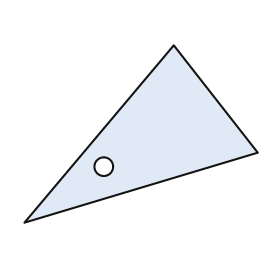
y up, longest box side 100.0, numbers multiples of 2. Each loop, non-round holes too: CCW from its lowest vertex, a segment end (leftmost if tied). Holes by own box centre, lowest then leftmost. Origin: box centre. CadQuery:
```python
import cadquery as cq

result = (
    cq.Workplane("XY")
    .moveTo(-50.0, -38.0)
    .lineTo(50.0, -8.0)
    .lineTo(14.0, 38.0)
    .close()
    .moveTo(-16.0, -14.0)
    .circle(4.0)
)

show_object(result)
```